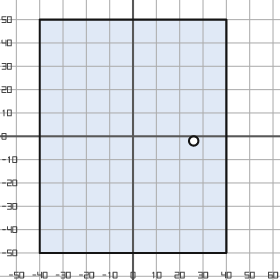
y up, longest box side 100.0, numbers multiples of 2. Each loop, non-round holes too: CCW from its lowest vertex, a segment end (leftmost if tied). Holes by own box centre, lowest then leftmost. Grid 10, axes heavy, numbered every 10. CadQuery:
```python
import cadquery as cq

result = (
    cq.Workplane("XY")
    .moveTo(-40.0, -50.0)
    .lineTo(40.0, -50.0)
    .lineTo(40.0, 50.0)
    .lineTo(-40.0, 50.0)
    .close()
    .moveTo(26.0, -2.0)
    .circle(2.0)
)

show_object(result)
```